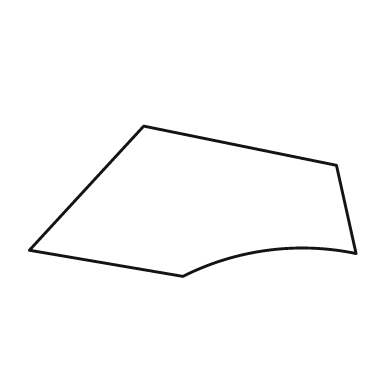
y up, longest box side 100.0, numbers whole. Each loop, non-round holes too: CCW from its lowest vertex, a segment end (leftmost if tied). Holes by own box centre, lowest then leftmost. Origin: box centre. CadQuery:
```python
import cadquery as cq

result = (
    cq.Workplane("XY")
    .moveTo(-3.0, -23.0)
    .threePointArc((23.0, -15.0), (50.0, -16.0))
    .lineTo(44.0, 11.0)
    .lineTo(-15.0, 23.0)
    .lineTo(-50.0, -15.0)
    .close()
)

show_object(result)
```